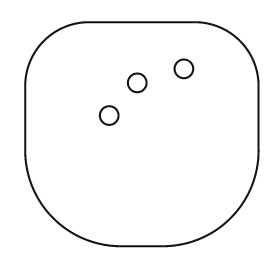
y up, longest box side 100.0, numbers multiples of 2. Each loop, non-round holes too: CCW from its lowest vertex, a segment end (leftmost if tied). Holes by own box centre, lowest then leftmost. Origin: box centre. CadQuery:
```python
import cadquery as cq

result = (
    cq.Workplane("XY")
    .moveTo(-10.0, -48.0)
    .lineTo(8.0, -48.0)
    .threePointArc((38.0, -36.0), (50.0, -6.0))
    .lineTo(50.0, 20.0)
    .threePointArc((42.0, 40.0), (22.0, 48.0))
    .lineTo(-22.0, 48.0)
    .threePointArc((-42.0, 40.0), (-50.0, 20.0))
    .lineTo(-50.0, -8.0)
    .threePointArc((-38.0, -36.0), (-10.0, -48.0))
    .close()
    .moveTo(-14.0, 8.0)
    .circle(4.0)
    .moveTo(-2.0, 22.0)
    .circle(4.0)
    .moveTo(18.0, 28.0)
    .circle(4.0)
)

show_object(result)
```